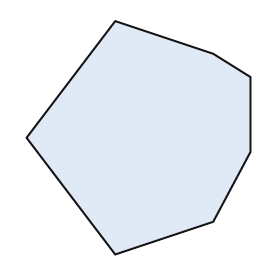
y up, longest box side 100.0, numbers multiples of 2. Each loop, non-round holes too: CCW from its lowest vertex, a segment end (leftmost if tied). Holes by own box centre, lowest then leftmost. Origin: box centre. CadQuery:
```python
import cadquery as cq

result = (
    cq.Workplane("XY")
    .moveTo(-10.0, -50.0)
    .lineTo(32.0, -36.0)
    .lineTo(48.0, -6.0)
    .lineTo(48.0, 26.0)
    .lineTo(32.0, 36.0)
    .lineTo(-10.0, 50.0)
    .lineTo(-48.0, 0.0)
    .close()
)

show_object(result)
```